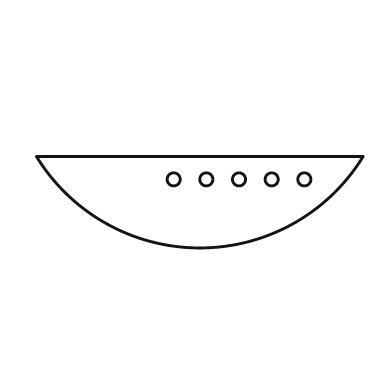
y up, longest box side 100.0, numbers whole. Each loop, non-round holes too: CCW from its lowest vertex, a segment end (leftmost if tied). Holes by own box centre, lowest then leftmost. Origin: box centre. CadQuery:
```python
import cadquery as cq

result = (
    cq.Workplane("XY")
    .moveTo(-50.0, 14.0)
    .threePointArc((0.0, -14.0), (50.0, 14.0))
    .close()
    .moveTo(-8.0, 7.0)
    .circle(2.0)
    .moveTo(2.0, 7.0)
    .circle(2.0)
    .moveTo(12.0, 7.0)
    .circle(2.0)
    .moveTo(22.0, 7.0)
    .circle(2.0)
    .moveTo(32.0, 7.0)
    .circle(2.0)
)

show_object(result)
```